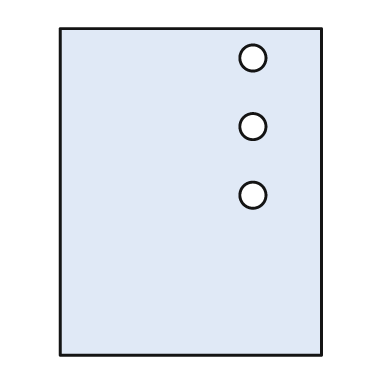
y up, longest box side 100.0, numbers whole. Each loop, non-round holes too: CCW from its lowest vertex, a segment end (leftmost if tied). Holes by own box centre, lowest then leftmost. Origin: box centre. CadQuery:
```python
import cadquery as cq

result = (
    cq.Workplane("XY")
    .moveTo(-40.0, -50.0)
    .lineTo(40.0, -50.0)
    .lineTo(40.0, 50.0)
    .lineTo(-40.0, 50.0)
    .close()
    .moveTo(19.0, -1.0)
    .circle(4.0)
    .moveTo(19.0, 20.0)
    .circle(4.0)
    .moveTo(19.0, 41.0)
    .circle(4.0)
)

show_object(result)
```